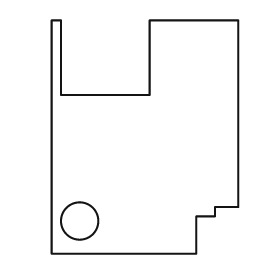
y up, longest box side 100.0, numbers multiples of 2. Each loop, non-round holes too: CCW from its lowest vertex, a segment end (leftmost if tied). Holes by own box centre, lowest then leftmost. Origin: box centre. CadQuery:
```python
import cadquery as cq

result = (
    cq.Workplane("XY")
    .moveTo(-40.0, -50.0)
    .lineTo(22.0, -50.0)
    .lineTo(22.0, -34.0)
    .lineTo(30.0, -34.0)
    .lineTo(30.0, -30.0)
    .lineTo(40.0, -30.0)
    .lineTo(40.0, 50.0)
    .lineTo(2.0, 50.0)
    .lineTo(2.0, 18.0)
    .lineTo(-36.0, 18.0)
    .lineTo(-36.0, 50.0)
    .lineTo(-40.0, 50.0)
    .close()
    .moveTo(-28.0, -36.0)
    .circle(8.0)
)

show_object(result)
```